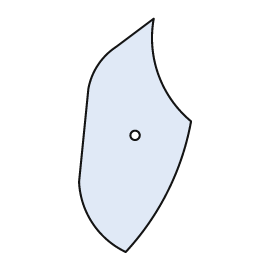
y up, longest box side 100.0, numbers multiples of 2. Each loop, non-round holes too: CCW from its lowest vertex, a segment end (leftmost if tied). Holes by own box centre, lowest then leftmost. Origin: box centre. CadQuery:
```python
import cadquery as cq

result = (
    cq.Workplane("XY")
    .moveTo(-4.0, -50.0)
    .threePointArc((14.0, -24.0), (24.0, 6.0))
    .threePointArc((10.0, 26.0), (8.0, 50.0))
    .lineTo(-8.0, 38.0)
    .threePointArc((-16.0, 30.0), (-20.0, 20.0))
    .lineTo(-24.0, -20.0)
    .threePointArc((-18.0, -38.0), (-4.0, -50.0))
    .close()
    .moveTo(0.0, 0.0)
    .circle(2.0)
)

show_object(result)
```